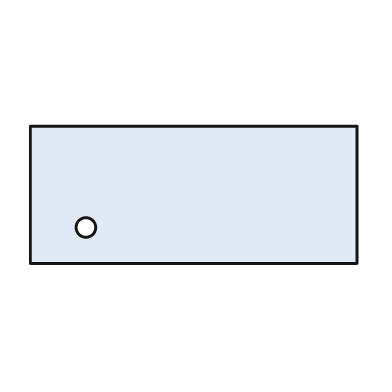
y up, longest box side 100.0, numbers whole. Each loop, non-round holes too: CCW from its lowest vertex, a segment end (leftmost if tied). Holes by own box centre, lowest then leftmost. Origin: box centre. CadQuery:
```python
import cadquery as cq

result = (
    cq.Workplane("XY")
    .moveTo(-50.0, -21.0)
    .lineTo(50.0, -21.0)
    .lineTo(50.0, 21.0)
    .lineTo(-50.0, 21.0)
    .close()
    .moveTo(-33.0, -10.0)
    .circle(3.0)
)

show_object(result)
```